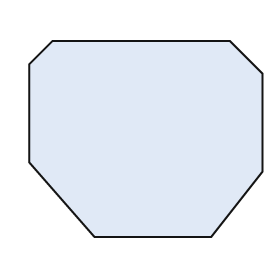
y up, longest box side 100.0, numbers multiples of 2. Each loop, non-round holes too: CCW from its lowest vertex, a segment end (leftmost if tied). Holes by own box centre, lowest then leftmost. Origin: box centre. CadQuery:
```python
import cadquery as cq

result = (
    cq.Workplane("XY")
    .moveTo(-22.0, -42.0)
    .lineTo(28.0, -42.0)
    .lineTo(50.0, -14.0)
    .lineTo(50.0, 28.0)
    .lineTo(36.0, 42.0)
    .lineTo(-40.0, 42.0)
    .lineTo(-50.0, 32.0)
    .lineTo(-50.0, -10.0)
    .close()
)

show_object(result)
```